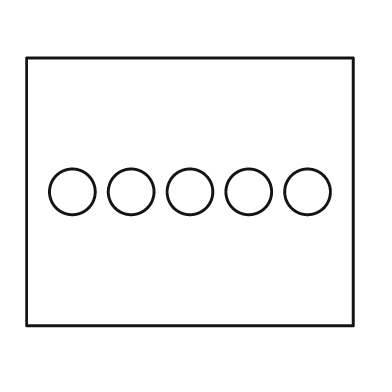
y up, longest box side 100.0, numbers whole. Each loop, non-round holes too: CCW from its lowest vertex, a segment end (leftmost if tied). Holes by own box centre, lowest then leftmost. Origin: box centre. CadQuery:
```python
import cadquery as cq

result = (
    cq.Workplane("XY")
    .moveTo(-50.0, -41.0)
    .lineTo(50.0, -41.0)
    .lineTo(50.0, 41.0)
    .lineTo(-50.0, 41.0)
    .close()
    .moveTo(-36.0, 0.0)
    .circle(7.0)
    .moveTo(-18.0, 0.0)
    .circle(7.0)
    .moveTo(0.0, 0.0)
    .circle(7.0)
    .moveTo(18.0, 0.0)
    .circle(7.0)
    .moveTo(36.0, 0.0)
    .circle(7.0)
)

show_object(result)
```